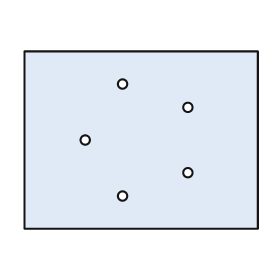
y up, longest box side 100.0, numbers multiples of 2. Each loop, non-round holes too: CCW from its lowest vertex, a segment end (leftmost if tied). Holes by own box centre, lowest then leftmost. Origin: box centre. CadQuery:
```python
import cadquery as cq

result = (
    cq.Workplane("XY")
    .moveTo(-50.0, -38.0)
    .lineTo(50.0, -38.0)
    .lineTo(50.0, 38.0)
    .lineTo(-50.0, 38.0)
    .close()
    .moveTo(-8.0, -24.0)
    .circle(2.0)
    .moveTo(20.0, -14.0)
    .circle(2.0)
    .moveTo(-24.0, 0.0)
    .circle(2.0)
    .moveTo(20.0, 14.0)
    .circle(2.0)
    .moveTo(-8.0, 24.0)
    .circle(2.0)
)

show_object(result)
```